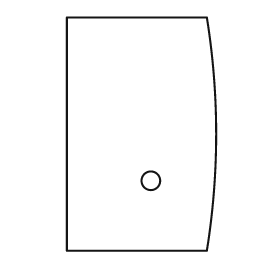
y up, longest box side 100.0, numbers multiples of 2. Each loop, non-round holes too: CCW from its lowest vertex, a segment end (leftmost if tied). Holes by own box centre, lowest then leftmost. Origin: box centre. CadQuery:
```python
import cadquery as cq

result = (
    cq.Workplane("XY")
    .moveTo(-32.0, -50.0)
    .lineTo(28.0, -50.0)
    .threePointArc((32.0, 0.0), (28.0, 50.0))
    .lineTo(-32.0, 50.0)
    .close()
    .moveTo(4.0, -20.0)
    .circle(4.0)
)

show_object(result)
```